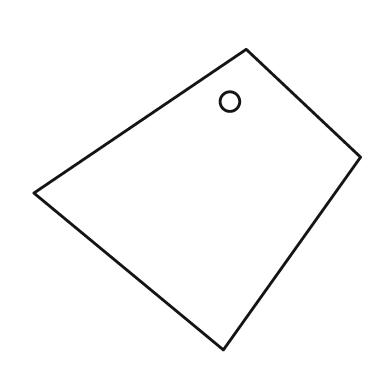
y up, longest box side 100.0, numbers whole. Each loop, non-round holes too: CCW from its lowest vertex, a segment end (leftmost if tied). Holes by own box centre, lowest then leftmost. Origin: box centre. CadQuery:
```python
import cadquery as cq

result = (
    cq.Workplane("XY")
    .moveTo(8.0, -46.0)
    .lineTo(50.0, 13.0)
    .lineTo(15.0, 46.0)
    .lineTo(-50.0, 2.0)
    .close()
    .moveTo(10.0, 30.0)
    .circle(3.0)
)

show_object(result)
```